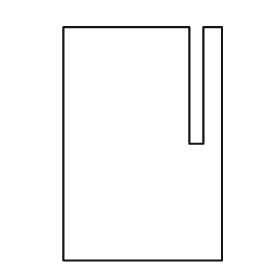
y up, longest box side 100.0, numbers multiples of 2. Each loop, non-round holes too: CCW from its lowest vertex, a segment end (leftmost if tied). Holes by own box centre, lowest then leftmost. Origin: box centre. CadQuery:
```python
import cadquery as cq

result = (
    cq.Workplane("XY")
    .moveTo(-34.0, -50.0)
    .lineTo(34.0, -50.0)
    .lineTo(34.0, 50.0)
    .lineTo(26.0, 50.0)
    .lineTo(26.0, 0.0)
    .lineTo(20.0, 0.0)
    .lineTo(20.0, 50.0)
    .lineTo(-34.0, 50.0)
    .close()
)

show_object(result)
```